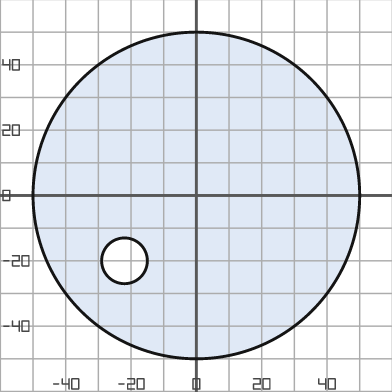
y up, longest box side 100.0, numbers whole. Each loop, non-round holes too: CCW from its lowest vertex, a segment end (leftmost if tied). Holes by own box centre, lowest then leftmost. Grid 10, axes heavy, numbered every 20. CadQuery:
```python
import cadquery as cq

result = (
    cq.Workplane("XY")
    .moveTo(0.0, 0.0)
    .circle(50.0)
    .moveTo(-22.0, -20.0)
    .circle(7.0)
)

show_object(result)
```